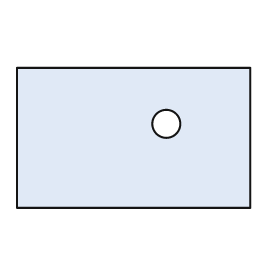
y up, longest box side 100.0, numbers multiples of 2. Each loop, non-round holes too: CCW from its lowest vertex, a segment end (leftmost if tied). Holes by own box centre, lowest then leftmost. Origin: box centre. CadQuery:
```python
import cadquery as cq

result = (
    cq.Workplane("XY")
    .moveTo(-50.0, -30.0)
    .lineTo(50.0, -30.0)
    .lineTo(50.0, 30.0)
    .lineTo(-50.0, 30.0)
    .close()
    .moveTo(14.0, 6.0)
    .circle(6.0)
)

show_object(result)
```